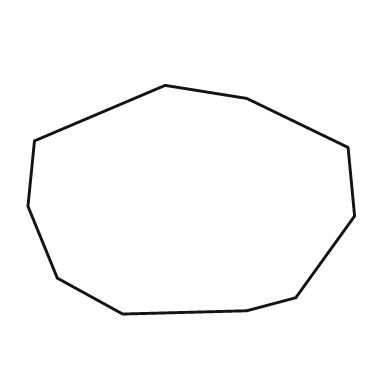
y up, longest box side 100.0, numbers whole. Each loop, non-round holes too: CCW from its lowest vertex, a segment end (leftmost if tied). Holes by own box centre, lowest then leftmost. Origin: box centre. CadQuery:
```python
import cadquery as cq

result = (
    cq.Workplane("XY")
    .moveTo(-21.0, -35.0)
    .lineTo(17.0, -34.0)
    .lineTo(32.0, -30.0)
    .lineTo(50.0, -5.0)
    .lineTo(48.0, 16.0)
    .lineTo(17.0, 31.0)
    .lineTo(-8.0, 35.0)
    .lineTo(-48.0, 18.0)
    .lineTo(-50.0, -2.0)
    .lineTo(-41.0, -24.0)
    .close()
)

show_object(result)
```